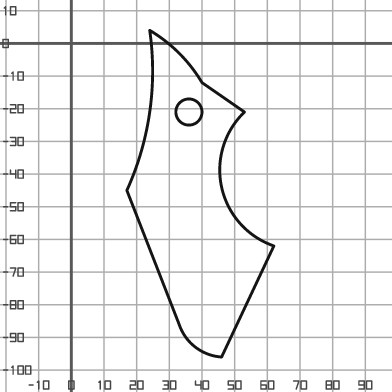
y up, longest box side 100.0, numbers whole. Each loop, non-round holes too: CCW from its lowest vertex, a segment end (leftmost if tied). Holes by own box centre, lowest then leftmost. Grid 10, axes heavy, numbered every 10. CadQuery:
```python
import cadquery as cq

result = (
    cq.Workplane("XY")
    .moveTo(46.0, -96.0)
    .lineTo(62.0, -62.0)
    .threePointArc((46.0, -44.0), (53.0, -21.0))
    .lineTo(40.0, -12.0)
    .threePointArc((33.0, -3.0), (24.0, 4.0))
    .threePointArc((24.0, -21.0), (17.0, -45.0))
    .lineTo(33.0, -86.0)
    .threePointArc((38.0, -93.0), (46.0, -96.0))
    .close()
    .moveTo(36.0, -21.0)
    .circle(4.0)
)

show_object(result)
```